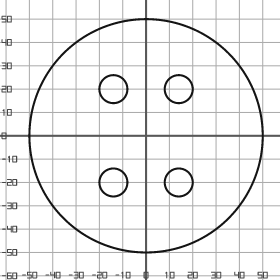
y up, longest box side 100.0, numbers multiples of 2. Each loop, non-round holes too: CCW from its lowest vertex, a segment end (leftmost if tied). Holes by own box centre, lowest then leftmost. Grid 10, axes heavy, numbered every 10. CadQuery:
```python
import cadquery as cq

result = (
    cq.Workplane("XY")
    .moveTo(0.0, 0.0)
    .circle(50.0)
    .moveTo(-14.0, -20.0)
    .circle(6.0)
    .moveTo(14.0, -20.0)
    .circle(6.0)
    .moveTo(-14.0, 20.0)
    .circle(6.0)
    .moveTo(14.0, 20.0)
    .circle(6.0)
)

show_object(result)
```